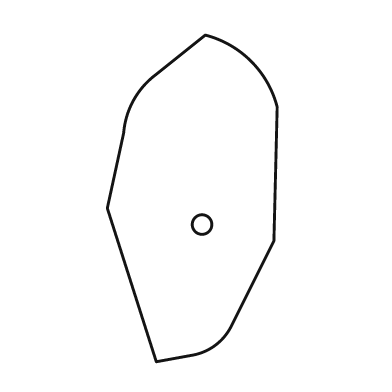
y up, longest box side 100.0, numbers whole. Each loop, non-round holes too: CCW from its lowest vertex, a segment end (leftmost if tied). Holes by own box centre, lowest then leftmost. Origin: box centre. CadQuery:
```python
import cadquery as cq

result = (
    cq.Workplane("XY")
    .moveTo(-11.0, -50.0)
    .lineTo(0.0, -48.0)
    .threePointArc((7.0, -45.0), (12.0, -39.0))
    .lineTo(25.0, -13.0)
    .lineTo(26.0, 28.0)
    .threePointArc((18.0, 42.0), (4.0, 50.0))
    .lineTo(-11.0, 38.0)
    .threePointArc((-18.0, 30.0), (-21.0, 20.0))
    .lineTo(-26.0, -3.0)
    .close()
    .moveTo(3.0, -8.0)
    .circle(3.0)
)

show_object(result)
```